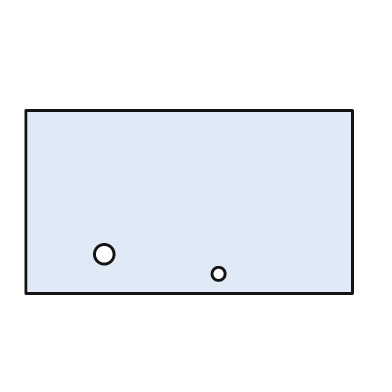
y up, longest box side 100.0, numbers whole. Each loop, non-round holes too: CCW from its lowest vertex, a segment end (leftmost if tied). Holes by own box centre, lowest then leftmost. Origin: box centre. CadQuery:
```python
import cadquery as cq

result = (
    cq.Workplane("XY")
    .moveTo(-50.0, -28.0)
    .lineTo(50.0, -28.0)
    .lineTo(50.0, 28.0)
    .lineTo(-50.0, 28.0)
    .close()
    .moveTo(9.0, -22.0)
    .circle(2.0)
    .moveTo(-26.0, -16.0)
    .circle(3.0)
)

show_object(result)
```